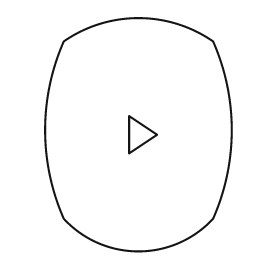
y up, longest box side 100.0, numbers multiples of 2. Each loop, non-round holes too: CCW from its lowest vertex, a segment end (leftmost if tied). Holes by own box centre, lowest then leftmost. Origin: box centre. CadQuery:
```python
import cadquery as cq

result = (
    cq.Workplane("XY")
    .moveTo(-32.0, -36.0)
    .threePointArc((0.0, -50.0), (32.0, -36.0))
    .threePointArc((40.0, 2.0), (32.0, 40.0))
    .threePointArc((0.0, 50.0), (-32.0, 40.0))
    .threePointArc((-40.0, 2.0), (-32.0, -36.0))
    .close()
    .moveTo(-4.0, -8.0)
    .lineTo(8.0, 0.0)
    .lineTo(-4.0, 8.0)
    .close()
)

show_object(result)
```